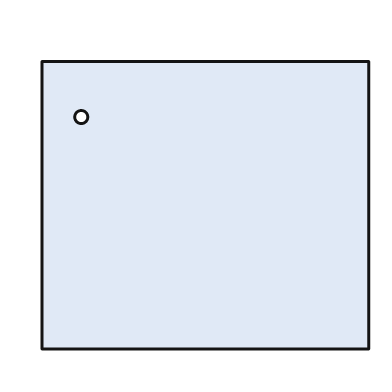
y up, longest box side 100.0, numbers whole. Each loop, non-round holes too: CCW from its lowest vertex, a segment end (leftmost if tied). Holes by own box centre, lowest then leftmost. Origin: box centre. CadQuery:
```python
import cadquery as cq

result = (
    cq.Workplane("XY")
    .moveTo(-50.0, -44.0)
    .lineTo(50.0, -44.0)
    .lineTo(50.0, 44.0)
    .lineTo(-50.0, 44.0)
    .close()
    .moveTo(-38.0, 27.0)
    .circle(2.0)
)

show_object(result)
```